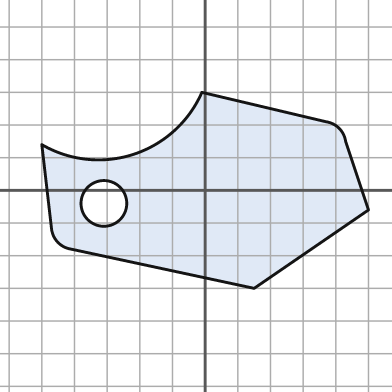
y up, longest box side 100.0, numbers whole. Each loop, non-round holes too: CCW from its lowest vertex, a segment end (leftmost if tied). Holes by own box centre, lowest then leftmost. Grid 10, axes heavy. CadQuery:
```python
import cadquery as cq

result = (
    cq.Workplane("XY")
    .moveTo(15.0, -30.0)
    .lineTo(50.0, -6.0)
    .lineTo(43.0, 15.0)
    .threePointArc((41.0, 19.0), (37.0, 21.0))
    .lineTo(-1.0, 30.0)
    .threePointArc((-22.0, 11.0), (-50.0, 14.0))
    .lineTo(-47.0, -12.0)
    .threePointArc((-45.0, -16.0), (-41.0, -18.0))
    .close()
    .moveTo(-31.0, -4.0)
    .circle(7.0)
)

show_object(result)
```